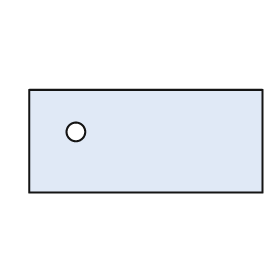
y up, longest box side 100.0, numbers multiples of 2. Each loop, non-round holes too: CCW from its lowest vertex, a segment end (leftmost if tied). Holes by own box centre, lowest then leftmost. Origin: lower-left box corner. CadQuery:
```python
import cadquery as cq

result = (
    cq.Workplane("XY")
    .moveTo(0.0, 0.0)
    .lineTo(100.0, 0.0)
    .lineTo(100.0, 44.0)
    .lineTo(0.0, 44.0)
    .close()
    .moveTo(20.0, 26.0)
    .circle(4.0)
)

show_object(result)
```